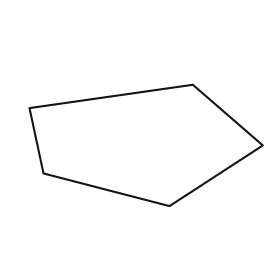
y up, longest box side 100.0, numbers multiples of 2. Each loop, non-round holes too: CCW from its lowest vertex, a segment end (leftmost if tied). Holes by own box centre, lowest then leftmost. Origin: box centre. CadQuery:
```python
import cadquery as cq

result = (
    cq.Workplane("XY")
    .moveTo(10.0, -26.0)
    .lineTo(50.0, 0.0)
    .lineTo(20.0, 26.0)
    .lineTo(-50.0, 16.0)
    .lineTo(-44.0, -12.0)
    .close()
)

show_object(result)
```